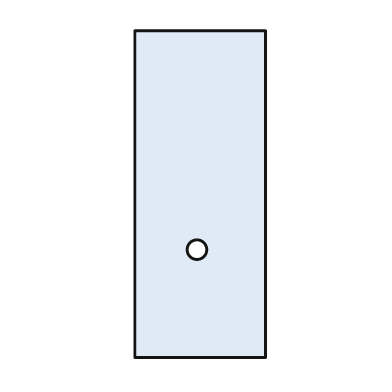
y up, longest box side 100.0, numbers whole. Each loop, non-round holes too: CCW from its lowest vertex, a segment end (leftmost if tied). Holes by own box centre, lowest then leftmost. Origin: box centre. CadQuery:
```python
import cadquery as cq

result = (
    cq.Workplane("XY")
    .moveTo(-20.0, -50.0)
    .lineTo(20.0, -50.0)
    .lineTo(20.0, 50.0)
    .lineTo(-20.0, 50.0)
    .close()
    .moveTo(-1.0, -17.0)
    .circle(3.0)
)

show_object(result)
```